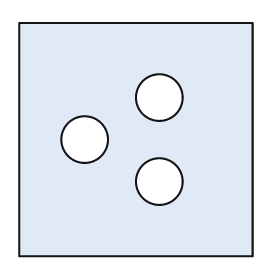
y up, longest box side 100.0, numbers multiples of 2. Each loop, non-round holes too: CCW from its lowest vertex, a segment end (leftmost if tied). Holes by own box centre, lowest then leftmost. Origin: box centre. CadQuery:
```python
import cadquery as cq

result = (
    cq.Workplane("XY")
    .moveTo(-50.0, -50.0)
    .lineTo(50.0, -50.0)
    .lineTo(50.0, 50.0)
    .lineTo(-50.0, 50.0)
    .close()
    .moveTo(10.0, -18.0)
    .circle(10.0)
    .moveTo(-22.0, 0.0)
    .circle(10.0)
    .moveTo(10.0, 18.0)
    .circle(10.0)
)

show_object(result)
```